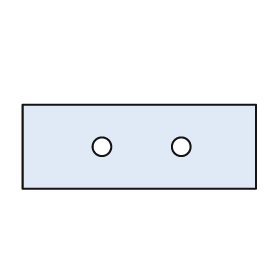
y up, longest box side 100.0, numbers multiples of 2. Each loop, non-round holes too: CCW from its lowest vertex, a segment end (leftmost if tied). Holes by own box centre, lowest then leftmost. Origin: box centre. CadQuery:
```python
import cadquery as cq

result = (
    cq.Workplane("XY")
    .moveTo(-50.0, -18.0)
    .lineTo(50.0, -18.0)
    .lineTo(50.0, 18.0)
    .lineTo(-50.0, 18.0)
    .close()
    .moveTo(-16.0, 0.0)
    .circle(4.0)
    .moveTo(18.0, 0.0)
    .circle(4.0)
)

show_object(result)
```